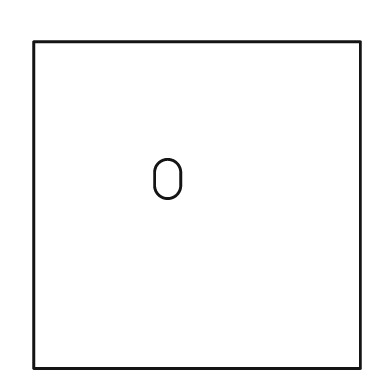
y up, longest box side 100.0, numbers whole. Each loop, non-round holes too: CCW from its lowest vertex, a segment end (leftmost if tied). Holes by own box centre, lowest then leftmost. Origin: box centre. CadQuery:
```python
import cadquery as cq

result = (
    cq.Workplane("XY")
    .moveTo(-50.0, -50.0)
    .lineTo(50.0, -50.0)
    .lineTo(50.0, 50.0)
    .lineTo(-50.0, 50.0)
    .close()
    .moveTo(-13.0, 6.0)
    .threePointArc((-9.0, 2.0), (-5.0, 6.0))
    .lineTo(-5.0, 10.0)
    .threePointArc((-9.0, 14.0), (-13.0, 10.0))
    .close()
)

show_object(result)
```